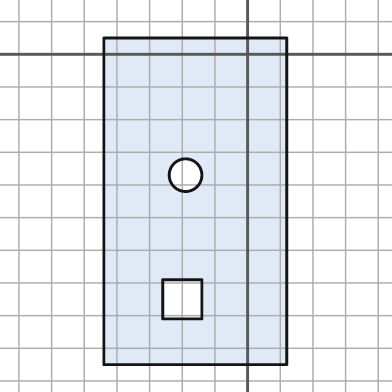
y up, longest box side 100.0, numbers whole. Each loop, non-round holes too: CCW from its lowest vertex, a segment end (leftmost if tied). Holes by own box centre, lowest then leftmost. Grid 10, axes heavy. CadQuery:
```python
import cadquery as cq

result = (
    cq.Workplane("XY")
    .moveTo(-44.0, -95.0)
    .lineTo(12.0, -95.0)
    .lineTo(12.0, 5.0)
    .lineTo(-44.0, 5.0)
    .close()
    .moveTo(-26.0, -81.0)
    .lineTo(-14.0, -81.0)
    .lineTo(-14.0, -69.0)
    .lineTo(-26.0, -69.0)
    .close()
    .moveTo(-19.0, -37.0)
    .circle(5.0)
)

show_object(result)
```